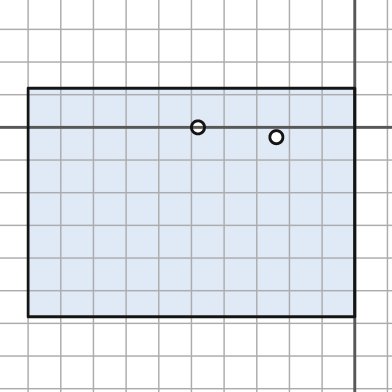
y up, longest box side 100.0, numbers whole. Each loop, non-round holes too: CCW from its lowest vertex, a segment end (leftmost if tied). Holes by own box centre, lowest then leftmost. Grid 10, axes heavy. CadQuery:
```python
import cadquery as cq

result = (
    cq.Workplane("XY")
    .moveTo(-100.0, -58.0)
    .lineTo(0.0, -58.0)
    .lineTo(0.0, 12.0)
    .lineTo(-100.0, 12.0)
    .close()
    .moveTo(-24.0, -3.0)
    .circle(2.0)
    .moveTo(-48.0, 0.0)
    .circle(2.0)
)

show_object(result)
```